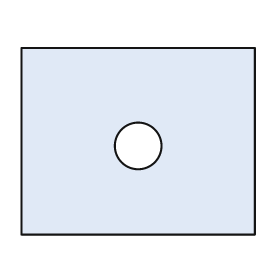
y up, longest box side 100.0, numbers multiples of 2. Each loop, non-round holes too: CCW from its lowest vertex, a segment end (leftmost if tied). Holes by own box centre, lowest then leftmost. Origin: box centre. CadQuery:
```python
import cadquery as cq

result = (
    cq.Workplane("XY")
    .moveTo(-50.0, -40.0)
    .lineTo(50.0, -40.0)
    .lineTo(50.0, 40.0)
    .lineTo(-50.0, 40.0)
    .close()
    .moveTo(0.0, -2.0)
    .circle(10.0)
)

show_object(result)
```